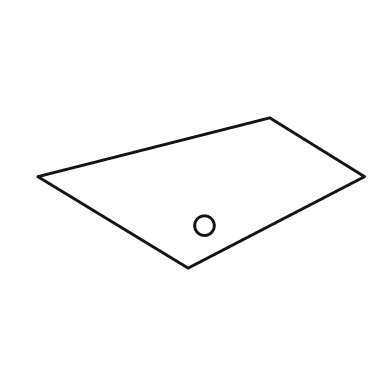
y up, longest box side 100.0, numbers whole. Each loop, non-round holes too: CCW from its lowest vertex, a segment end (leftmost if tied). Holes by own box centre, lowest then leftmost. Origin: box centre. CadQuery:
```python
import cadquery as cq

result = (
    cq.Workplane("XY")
    .moveTo(-4.0, -23.0)
    .lineTo(50.0, 5.0)
    .lineTo(21.0, 23.0)
    .lineTo(-50.0, 5.0)
    .close()
    .moveTo(1.0, -10.0)
    .circle(3.0)
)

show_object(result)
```